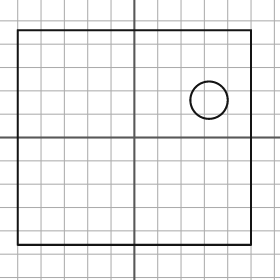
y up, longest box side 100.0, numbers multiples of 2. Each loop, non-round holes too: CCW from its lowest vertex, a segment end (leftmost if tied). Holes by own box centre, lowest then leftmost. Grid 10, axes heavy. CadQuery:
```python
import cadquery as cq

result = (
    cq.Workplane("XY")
    .moveTo(-50.0, -46.0)
    .lineTo(50.0, -46.0)
    .lineTo(50.0, 46.0)
    .lineTo(-50.0, 46.0)
    .close()
    .moveTo(32.0, 16.0)
    .circle(8.0)
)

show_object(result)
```